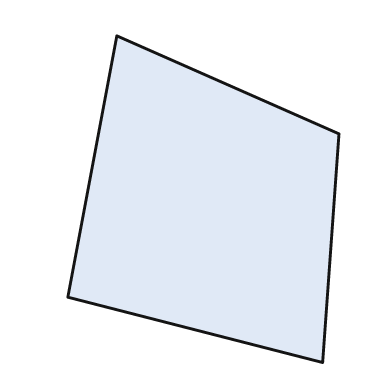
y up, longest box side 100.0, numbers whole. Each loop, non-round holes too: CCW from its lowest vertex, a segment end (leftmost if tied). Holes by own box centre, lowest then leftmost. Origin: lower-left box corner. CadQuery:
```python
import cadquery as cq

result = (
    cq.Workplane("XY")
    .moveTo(78.0, 0.0)
    .lineTo(83.0, 70.0)
    .lineTo(15.0, 100.0)
    .lineTo(0.0, 20.0)
    .close()
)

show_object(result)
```